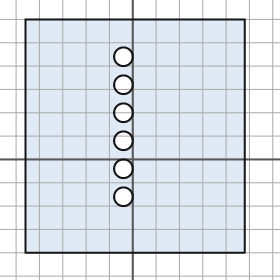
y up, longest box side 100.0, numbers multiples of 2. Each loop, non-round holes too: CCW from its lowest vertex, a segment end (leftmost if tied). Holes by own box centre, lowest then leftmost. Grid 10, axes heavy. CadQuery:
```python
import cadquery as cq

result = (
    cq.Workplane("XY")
    .moveTo(-46.0, -40.0)
    .lineTo(48.0, -40.0)
    .lineTo(48.0, 60.0)
    .lineTo(-46.0, 60.0)
    .close()
    .moveTo(-4.0, -16.0)
    .circle(4.0)
    .moveTo(-4.0, -4.0)
    .circle(4.0)
    .moveTo(-4.0, 8.0)
    .circle(4.0)
    .moveTo(-4.0, 20.0)
    .circle(4.0)
    .moveTo(-4.0, 32.0)
    .circle(4.0)
    .moveTo(-4.0, 44.0)
    .circle(4.0)
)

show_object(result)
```